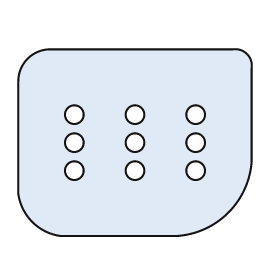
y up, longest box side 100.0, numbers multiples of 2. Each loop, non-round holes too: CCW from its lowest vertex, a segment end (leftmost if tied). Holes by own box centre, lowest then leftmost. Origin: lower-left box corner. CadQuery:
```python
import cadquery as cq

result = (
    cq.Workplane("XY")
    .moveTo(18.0, 0.0)
    .lineTo(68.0, 0.0)
    .threePointArc((90.0, 10.0), (100.0, 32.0))
    .lineTo(100.0, 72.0)
    .threePointArc((98.0, 78.0), (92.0, 80.0))
    .lineTo(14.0, 80.0)
    .threePointArc((4.0, 76.0), (0.0, 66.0))
    .lineTo(0.0, 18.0)
    .threePointArc((6.0, 6.0), (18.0, 0.0))
    .close()
    .moveTo(24.0, 28.0)
    .circle(4.0)
    .moveTo(50.0, 28.0)
    .circle(4.0)
    .moveTo(76.0, 28.0)
    .circle(4.0)
    .moveTo(24.0, 40.0)
    .circle(4.0)
    .moveTo(50.0, 40.0)
    .circle(4.0)
    .moveTo(76.0, 40.0)
    .circle(4.0)
    .moveTo(24.0, 52.0)
    .circle(4.0)
    .moveTo(50.0, 52.0)
    .circle(4.0)
    .moveTo(76.0, 52.0)
    .circle(4.0)
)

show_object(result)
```